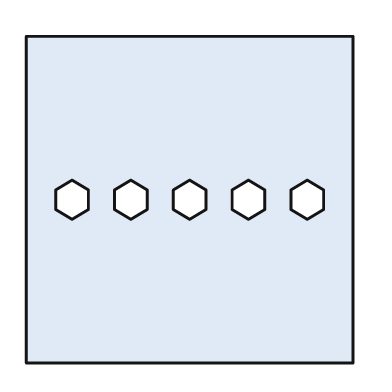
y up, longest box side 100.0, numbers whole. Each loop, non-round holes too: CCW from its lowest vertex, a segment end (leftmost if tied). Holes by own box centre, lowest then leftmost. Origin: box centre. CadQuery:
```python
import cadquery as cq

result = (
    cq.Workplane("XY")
    .moveTo(-50.0, -50.0)
    .lineTo(50.0, -50.0)
    .lineTo(50.0, 50.0)
    .lineTo(-50.0, 50.0)
    .close()
    .moveTo(-36.0, -6.0)
    .lineTo(-31.0, -3.0)
    .lineTo(-31.0, 3.0)
    .lineTo(-36.0, 6.0)
    .lineTo(-41.0, 3.0)
    .lineTo(-41.0, -3.0)
    .close()
    .moveTo(-18.0, -6.0)
    .lineTo(-13.0, -3.0)
    .lineTo(-13.0, 3.0)
    .lineTo(-18.0, 6.0)
    .lineTo(-23.0, 3.0)
    .lineTo(-23.0, -3.0)
    .close()
    .moveTo(0.0, -6.0)
    .lineTo(5.0, -3.0)
    .lineTo(5.0, 3.0)
    .lineTo(0.0, 6.0)
    .lineTo(-5.0, 3.0)
    .lineTo(-5.0, -3.0)
    .close()
    .moveTo(18.0, -6.0)
    .lineTo(23.0, -3.0)
    .lineTo(23.0, 3.0)
    .lineTo(18.0, 6.0)
    .lineTo(13.0, 3.0)
    .lineTo(13.0, -3.0)
    .close()
    .moveTo(36.0, -6.0)
    .lineTo(41.0, -3.0)
    .lineTo(41.0, 3.0)
    .lineTo(36.0, 6.0)
    .lineTo(31.0, 3.0)
    .lineTo(31.0, -3.0)
    .close()
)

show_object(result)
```